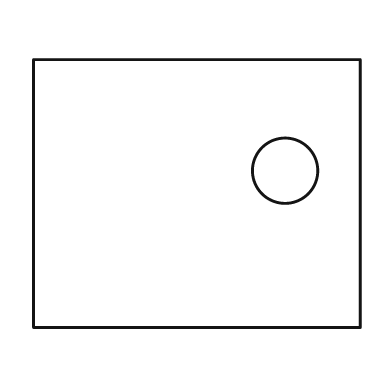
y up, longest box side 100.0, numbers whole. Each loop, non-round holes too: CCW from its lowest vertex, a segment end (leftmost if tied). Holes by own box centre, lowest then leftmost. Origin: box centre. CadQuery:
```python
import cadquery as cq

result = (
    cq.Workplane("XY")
    .moveTo(-50.0, -41.0)
    .lineTo(50.0, -41.0)
    .lineTo(50.0, 41.0)
    .lineTo(-50.0, 41.0)
    .close()
    .moveTo(27.0, 7.0)
    .circle(10.0)
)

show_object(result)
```